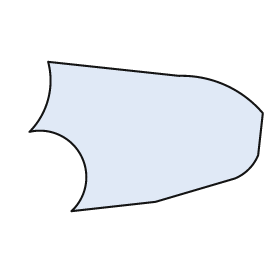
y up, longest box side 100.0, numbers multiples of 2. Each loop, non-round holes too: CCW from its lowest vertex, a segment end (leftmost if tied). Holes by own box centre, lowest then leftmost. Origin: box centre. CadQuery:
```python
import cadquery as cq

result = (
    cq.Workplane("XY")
    .moveTo(-32.0, -32.0)
    .lineTo(4.0, -28.0)
    .lineTo(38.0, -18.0)
    .threePointArc((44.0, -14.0), (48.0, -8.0))
    .lineTo(50.0, 10.0)
    .threePointArc((34.0, 22.0), (14.0, 26.0))
    .lineTo(-42.0, 32.0)
    .threePointArc((-42.0, 16.0), (-50.0, 2.0))
    .threePointArc((-28.0, -8.0), (-32.0, -32.0))
    .close()
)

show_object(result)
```